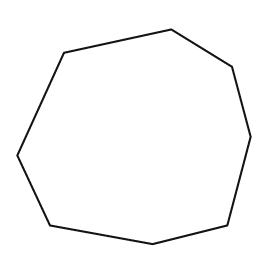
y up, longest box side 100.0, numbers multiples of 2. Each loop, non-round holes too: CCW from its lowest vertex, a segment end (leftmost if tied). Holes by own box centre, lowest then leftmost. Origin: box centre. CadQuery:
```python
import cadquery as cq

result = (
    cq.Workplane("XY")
    .moveTo(8.0, -46.0)
    .lineTo(40.0, -38.0)
    .lineTo(50.0, 0.0)
    .lineTo(42.0, 30.0)
    .lineTo(16.0, 46.0)
    .lineTo(-30.0, 36.0)
    .lineTo(-50.0, -8.0)
    .lineTo(-36.0, -38.0)
    .close()
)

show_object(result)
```